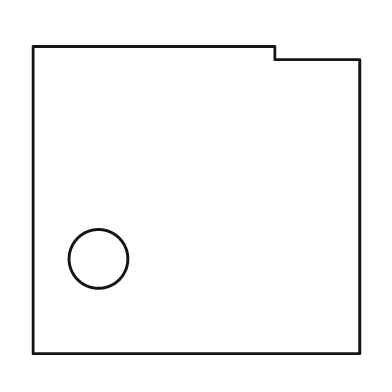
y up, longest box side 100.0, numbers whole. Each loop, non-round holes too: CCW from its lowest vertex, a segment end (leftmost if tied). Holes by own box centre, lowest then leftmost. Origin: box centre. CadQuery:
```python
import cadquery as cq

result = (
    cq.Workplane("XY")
    .moveTo(-50.0, -47.0)
    .lineTo(50.0, -47.0)
    .lineTo(50.0, 43.0)
    .lineTo(24.0, 43.0)
    .lineTo(24.0, 47.0)
    .lineTo(-50.0, 47.0)
    .close()
    .moveTo(-30.0, -18.0)
    .circle(9.0)
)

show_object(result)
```